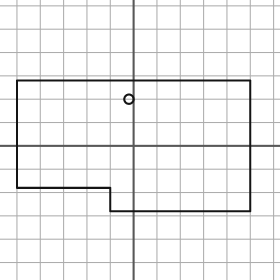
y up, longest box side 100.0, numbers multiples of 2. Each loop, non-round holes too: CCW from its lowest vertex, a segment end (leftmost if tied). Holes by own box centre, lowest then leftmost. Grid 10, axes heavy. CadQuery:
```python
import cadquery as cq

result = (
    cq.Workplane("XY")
    .moveTo(-10.0, -28.0)
    .lineTo(50.0, -28.0)
    .lineTo(50.0, 28.0)
    .lineTo(-50.0, 28.0)
    .lineTo(-50.0, -18.0)
    .lineTo(-10.0, -18.0)
    .close()
    .moveTo(-2.0, 20.0)
    .circle(2.0)
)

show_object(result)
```